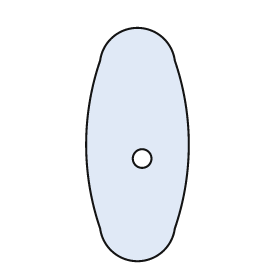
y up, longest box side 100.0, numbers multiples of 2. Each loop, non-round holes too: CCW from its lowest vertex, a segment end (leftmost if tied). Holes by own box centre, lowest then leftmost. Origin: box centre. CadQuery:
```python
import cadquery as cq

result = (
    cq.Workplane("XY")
    .moveTo(-16.0, -36.0)
    .threePointArc((0.0, -50.0), (16.0, -36.0))
    .threePointArc((22.0, 0.0), (16.0, 36.0))
    .threePointArc((0.0, 50.0), (-16.0, 36.0))
    .threePointArc((-22.0, 0.0), (-16.0, -36.0))
    .close()
    .moveTo(2.0, -6.0)
    .circle(4.0)
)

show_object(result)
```